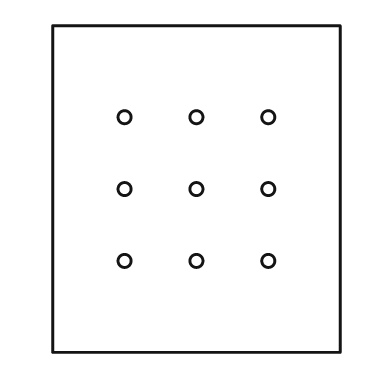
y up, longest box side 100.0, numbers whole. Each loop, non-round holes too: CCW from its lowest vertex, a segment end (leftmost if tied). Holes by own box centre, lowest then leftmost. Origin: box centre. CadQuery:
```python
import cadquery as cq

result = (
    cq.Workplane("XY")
    .moveTo(-44.0, -50.0)
    .lineTo(44.0, -50.0)
    .lineTo(44.0, 50.0)
    .lineTo(-44.0, 50.0)
    .close()
    .moveTo(-22.0, -22.0)
    .circle(2.0)
    .moveTo(0.0, -22.0)
    .circle(2.0)
    .moveTo(22.0, -22.0)
    .circle(2.0)
    .moveTo(-22.0, 0.0)
    .circle(2.0)
    .moveTo(0.0, 0.0)
    .circle(2.0)
    .moveTo(22.0, 0.0)
    .circle(2.0)
    .moveTo(-22.0, 22.0)
    .circle(2.0)
    .moveTo(0.0, 22.0)
    .circle(2.0)
    .moveTo(22.0, 22.0)
    .circle(2.0)
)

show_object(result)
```